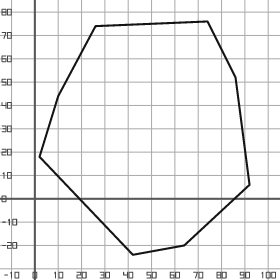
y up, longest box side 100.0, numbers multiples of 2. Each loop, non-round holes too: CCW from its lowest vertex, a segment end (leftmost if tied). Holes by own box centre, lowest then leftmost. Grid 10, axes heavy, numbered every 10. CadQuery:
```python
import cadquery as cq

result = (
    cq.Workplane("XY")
    .moveTo(42.0, -24.0)
    .lineTo(64.0, -20.0)
    .lineTo(92.0, 6.0)
    .lineTo(86.0, 52.0)
    .lineTo(74.0, 76.0)
    .lineTo(26.0, 74.0)
    .lineTo(10.0, 44.0)
    .lineTo(2.0, 18.0)
    .close()
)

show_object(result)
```